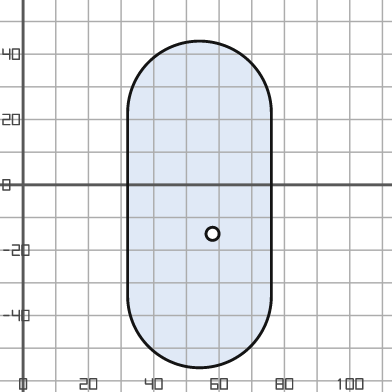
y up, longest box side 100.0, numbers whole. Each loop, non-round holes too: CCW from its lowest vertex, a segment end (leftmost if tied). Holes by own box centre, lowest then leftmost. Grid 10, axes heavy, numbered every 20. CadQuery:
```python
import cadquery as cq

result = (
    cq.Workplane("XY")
    .moveTo(32.0, -34.0)
    .threePointArc((54.0, -56.0), (76.0, -34.0))
    .lineTo(76.0, 22.0)
    .threePointArc((54.0, 44.0), (32.0, 22.0))
    .close()
    .moveTo(58.0, -15.0)
    .circle(2.0)
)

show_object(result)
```